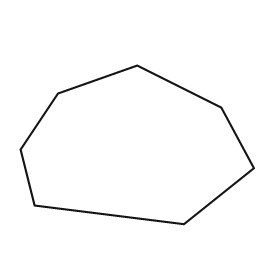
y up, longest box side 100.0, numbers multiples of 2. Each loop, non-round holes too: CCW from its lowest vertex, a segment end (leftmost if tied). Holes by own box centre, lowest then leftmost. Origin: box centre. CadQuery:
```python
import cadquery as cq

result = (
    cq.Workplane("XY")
    .moveTo(20.0, -34.0)
    .lineTo(50.0, -10.0)
    .lineTo(36.0, 16.0)
    .lineTo(0.0, 34.0)
    .lineTo(-34.0, 22.0)
    .lineTo(-50.0, -2.0)
    .lineTo(-44.0, -26.0)
    .close()
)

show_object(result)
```